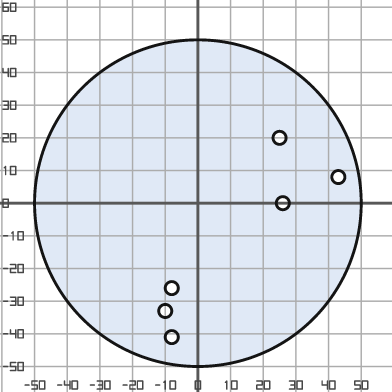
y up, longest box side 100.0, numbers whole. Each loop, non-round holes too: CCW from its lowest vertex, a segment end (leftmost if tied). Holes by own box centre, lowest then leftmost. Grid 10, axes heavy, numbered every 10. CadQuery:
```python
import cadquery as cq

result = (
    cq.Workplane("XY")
    .moveTo(0.0, 0.0)
    .circle(50.0)
    .moveTo(-8.0, -41.0)
    .circle(2.0)
    .moveTo(-10.0, -33.0)
    .circle(2.0)
    .moveTo(-8.0, -26.0)
    .circle(2.0)
    .moveTo(26.0, 0.0)
    .circle(2.0)
    .moveTo(43.0, 8.0)
    .circle(2.0)
    .moveTo(25.0, 20.0)
    .circle(2.0)
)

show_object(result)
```